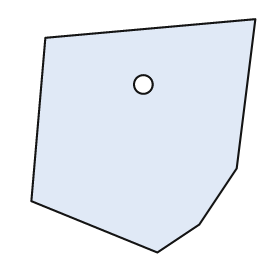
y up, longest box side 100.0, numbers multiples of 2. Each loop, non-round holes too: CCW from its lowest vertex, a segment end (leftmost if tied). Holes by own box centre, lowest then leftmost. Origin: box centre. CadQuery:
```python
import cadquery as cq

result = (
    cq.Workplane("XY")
    .moveTo(6.0, -50.0)
    .lineTo(24.0, -38.0)
    .lineTo(40.0, -14.0)
    .lineTo(48.0, 50.0)
    .lineTo(-42.0, 42.0)
    .lineTo(-48.0, -28.0)
    .close()
    .moveTo(0.0, 22.0)
    .circle(4.0)
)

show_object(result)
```